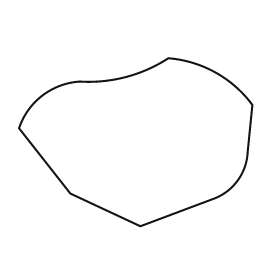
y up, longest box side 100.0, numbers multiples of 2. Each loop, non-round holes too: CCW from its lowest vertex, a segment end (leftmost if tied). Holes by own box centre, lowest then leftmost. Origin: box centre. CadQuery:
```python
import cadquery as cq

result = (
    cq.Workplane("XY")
    .moveTo(2.0, -36.0)
    .lineTo(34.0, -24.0)
    .threePointArc((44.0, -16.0), (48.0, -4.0))
    .lineTo(50.0, 16.0)
    .threePointArc((34.0, 30.0), (14.0, 36.0))
    .threePointArc((-4.0, 28.0), (-24.0, 26.0))
    .threePointArc((-40.0, 20.0), (-50.0, 6.0))
    .lineTo(-28.0, -22.0)
    .close()
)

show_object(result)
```